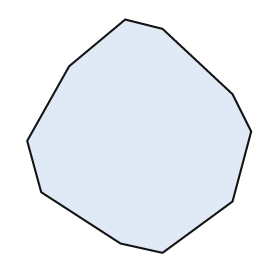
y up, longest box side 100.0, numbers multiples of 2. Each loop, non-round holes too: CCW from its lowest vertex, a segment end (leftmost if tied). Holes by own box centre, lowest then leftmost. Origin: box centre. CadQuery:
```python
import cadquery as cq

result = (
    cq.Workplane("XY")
    .moveTo(10.0, -50.0)
    .lineTo(40.0, -28.0)
    .lineTo(48.0, 2.0)
    .lineTo(40.0, 18.0)
    .lineTo(10.0, 46.0)
    .lineTo(-6.0, 50.0)
    .lineTo(-30.0, 30.0)
    .lineTo(-48.0, -2.0)
    .lineTo(-42.0, -24.0)
    .lineTo(-8.0, -46.0)
    .close()
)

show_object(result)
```